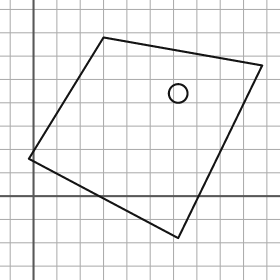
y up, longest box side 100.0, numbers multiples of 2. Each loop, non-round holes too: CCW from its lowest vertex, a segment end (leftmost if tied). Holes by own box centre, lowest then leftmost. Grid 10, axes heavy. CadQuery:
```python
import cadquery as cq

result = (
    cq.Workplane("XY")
    .moveTo(62.0, -18.0)
    .lineTo(98.0, 56.0)
    .lineTo(30.0, 68.0)
    .lineTo(-2.0, 16.0)
    .close()
    .moveTo(62.0, 44.0)
    .circle(4.0)
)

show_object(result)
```